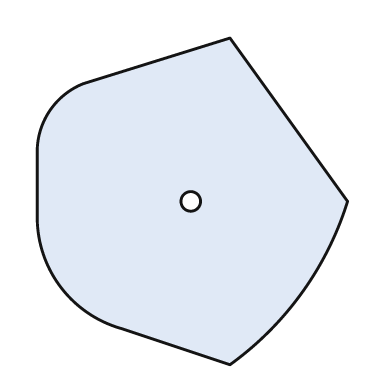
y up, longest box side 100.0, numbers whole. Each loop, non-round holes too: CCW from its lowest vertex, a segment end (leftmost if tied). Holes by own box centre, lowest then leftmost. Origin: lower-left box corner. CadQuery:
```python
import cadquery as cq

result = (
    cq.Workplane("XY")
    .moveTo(59.0, 0.0)
    .threePointArc((81.0, 22.0), (95.0, 50.0))
    .lineTo(59.0, 100.0)
    .lineTo(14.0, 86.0)
    .threePointArc((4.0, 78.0), (0.0, 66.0))
    .lineTo(0.0, 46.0)
    .threePointArc((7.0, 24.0), (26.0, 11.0))
    .close()
    .moveTo(47.0, 50.0)
    .circle(3.0)
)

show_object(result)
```